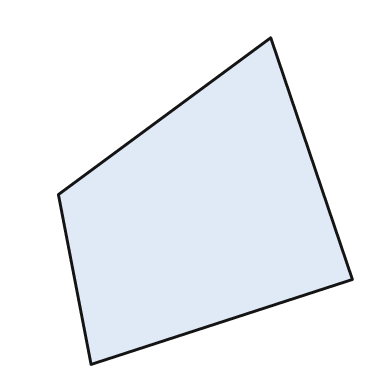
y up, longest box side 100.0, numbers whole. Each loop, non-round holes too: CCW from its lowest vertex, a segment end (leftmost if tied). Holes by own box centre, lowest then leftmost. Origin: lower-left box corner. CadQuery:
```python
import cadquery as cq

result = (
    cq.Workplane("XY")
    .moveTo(10.0, 0.0)
    .lineTo(90.0, 26.0)
    .lineTo(65.0, 100.0)
    .lineTo(0.0, 52.0)
    .close()
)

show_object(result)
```